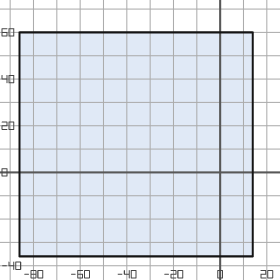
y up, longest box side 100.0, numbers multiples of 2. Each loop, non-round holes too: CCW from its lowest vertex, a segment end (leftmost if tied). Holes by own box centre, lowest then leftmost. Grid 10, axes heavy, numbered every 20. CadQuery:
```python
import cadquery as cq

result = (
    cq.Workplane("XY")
    .moveTo(-86.0, -36.0)
    .lineTo(14.0, -36.0)
    .lineTo(14.0, 60.0)
    .lineTo(-86.0, 60.0)
    .close()
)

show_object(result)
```